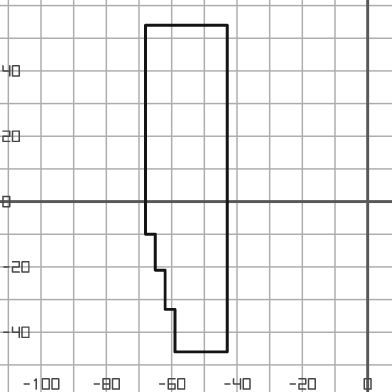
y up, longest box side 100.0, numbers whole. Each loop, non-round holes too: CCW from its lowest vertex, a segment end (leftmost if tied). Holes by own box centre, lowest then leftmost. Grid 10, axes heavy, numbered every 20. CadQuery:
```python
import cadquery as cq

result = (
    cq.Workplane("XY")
    .moveTo(-59.0, -46.0)
    .lineTo(-43.0, -46.0)
    .lineTo(-43.0, 54.0)
    .lineTo(-68.0, 54.0)
    .lineTo(-68.0, -10.0)
    .lineTo(-65.0, -10.0)
    .lineTo(-65.0, -21.0)
    .lineTo(-62.0, -21.0)
    .lineTo(-62.0, -33.0)
    .lineTo(-59.0, -33.0)
    .close()
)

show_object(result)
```